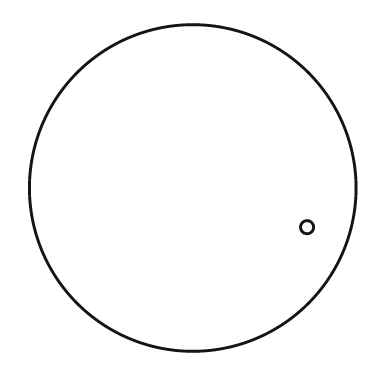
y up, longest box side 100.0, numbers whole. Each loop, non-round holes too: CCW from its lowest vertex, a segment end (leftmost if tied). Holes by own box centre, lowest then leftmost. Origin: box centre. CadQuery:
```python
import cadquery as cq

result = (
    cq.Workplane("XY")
    .moveTo(0.0, 0.0)
    .circle(50.0)
    .moveTo(35.0, -12.0)
    .circle(2.0)
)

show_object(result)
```